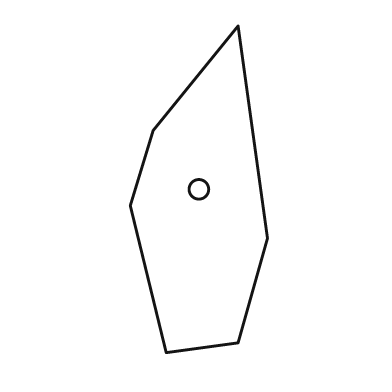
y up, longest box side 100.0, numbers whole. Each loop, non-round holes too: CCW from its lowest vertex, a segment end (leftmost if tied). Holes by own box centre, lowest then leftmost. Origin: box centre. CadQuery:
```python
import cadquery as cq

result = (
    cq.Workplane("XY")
    .moveTo(-10.0, -50.0)
    .lineTo(12.0, -47.0)
    .lineTo(21.0, -15.0)
    .lineTo(12.0, 50.0)
    .lineTo(-14.0, 18.0)
    .lineTo(-21.0, -5.0)
    .close()
    .moveTo(0.0, 0.0)
    .circle(3.0)
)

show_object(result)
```